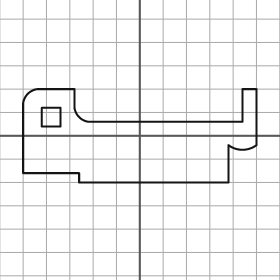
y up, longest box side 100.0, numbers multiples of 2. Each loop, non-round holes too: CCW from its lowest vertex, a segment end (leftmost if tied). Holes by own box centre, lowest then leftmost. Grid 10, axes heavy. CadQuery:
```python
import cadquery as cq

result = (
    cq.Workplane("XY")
    .moveTo(-26.0, -20.0)
    .lineTo(38.0, -20.0)
    .lineTo(38.0, -4.0)
    .threePointArc((44.0, -6.0), (50.0, -4.0))
    .lineTo(50.0, 20.0)
    .lineTo(44.0, 20.0)
    .lineTo(44.0, 6.0)
    .lineTo(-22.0, 6.0)
    .threePointArc((-26.0, 8.0), (-28.0, 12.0))
    .lineTo(-28.0, 20.0)
    .lineTo(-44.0, 20.0)
    .threePointArc((-48.0, 18.0), (-50.0, 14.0))
    .lineTo(-50.0, -16.0)
    .lineTo(-26.0, -16.0)
    .close()
    .moveTo(-42.0, 4.0)
    .lineTo(-34.0, 4.0)
    .lineTo(-34.0, 12.0)
    .lineTo(-42.0, 12.0)
    .close()
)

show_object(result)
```